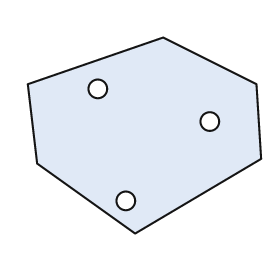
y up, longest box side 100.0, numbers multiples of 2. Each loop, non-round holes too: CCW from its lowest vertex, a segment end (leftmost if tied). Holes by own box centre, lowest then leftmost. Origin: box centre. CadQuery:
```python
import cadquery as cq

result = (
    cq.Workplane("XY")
    .moveTo(-4.0, -42.0)
    .lineTo(50.0, -10.0)
    .lineTo(48.0, 22.0)
    .lineTo(8.0, 42.0)
    .lineTo(-50.0, 22.0)
    .lineTo(-46.0, -12.0)
    .close()
    .moveTo(-8.0, -28.0)
    .circle(4.0)
    .moveTo(28.0, 6.0)
    .circle(4.0)
    .moveTo(-20.0, 20.0)
    .circle(4.0)
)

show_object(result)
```